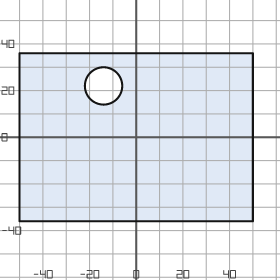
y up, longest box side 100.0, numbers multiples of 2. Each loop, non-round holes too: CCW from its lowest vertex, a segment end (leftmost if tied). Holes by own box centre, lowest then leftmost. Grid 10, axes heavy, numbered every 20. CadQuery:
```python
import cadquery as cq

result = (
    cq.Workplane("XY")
    .moveTo(-50.0, -36.0)
    .lineTo(50.0, -36.0)
    .lineTo(50.0, 36.0)
    .lineTo(-50.0, 36.0)
    .close()
    .moveTo(-14.0, 22.0)
    .circle(8.0)
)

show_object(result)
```